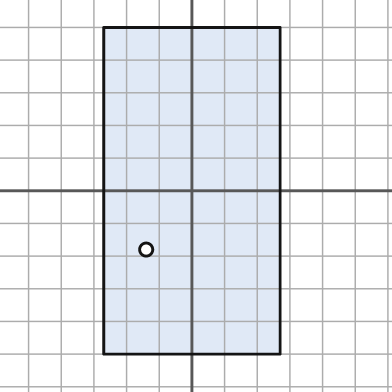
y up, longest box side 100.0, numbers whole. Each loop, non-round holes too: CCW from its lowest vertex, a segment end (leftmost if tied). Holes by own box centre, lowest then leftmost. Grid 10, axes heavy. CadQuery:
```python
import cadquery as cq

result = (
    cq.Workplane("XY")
    .moveTo(-27.0, -50.0)
    .lineTo(27.0, -50.0)
    .lineTo(27.0, 50.0)
    .lineTo(-27.0, 50.0)
    .close()
    .moveTo(-14.0, -18.0)
    .circle(2.0)
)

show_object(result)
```